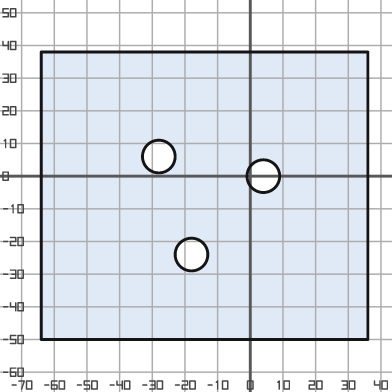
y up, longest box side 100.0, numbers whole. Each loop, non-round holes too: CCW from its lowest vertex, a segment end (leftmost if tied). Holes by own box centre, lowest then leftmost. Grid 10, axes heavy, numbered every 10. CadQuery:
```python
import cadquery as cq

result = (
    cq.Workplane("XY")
    .moveTo(-64.0, -50.0)
    .lineTo(36.0, -50.0)
    .lineTo(36.0, 38.0)
    .lineTo(-64.0, 38.0)
    .close()
    .moveTo(-18.0, -24.0)
    .circle(5.0)
    .moveTo(4.0, 0.0)
    .circle(5.0)
    .moveTo(-28.0, 6.0)
    .circle(5.0)
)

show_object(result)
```